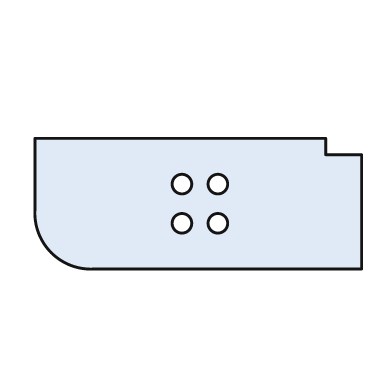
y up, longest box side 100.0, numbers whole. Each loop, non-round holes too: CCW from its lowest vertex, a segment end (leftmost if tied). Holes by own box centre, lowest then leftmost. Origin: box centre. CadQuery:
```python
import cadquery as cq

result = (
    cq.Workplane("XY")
    .moveTo(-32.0, -20.0)
    .lineTo(50.0, -20.0)
    .lineTo(50.0, 15.0)
    .lineTo(39.0, 15.0)
    .lineTo(39.0, 20.0)
    .lineTo(-50.0, 20.0)
    .lineTo(-50.0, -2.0)
    .threePointArc((-45.0, -15.0), (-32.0, -20.0))
    .close()
    .moveTo(-5.0, -6.0)
    .circle(3.0)
    .moveTo(6.0, -6.0)
    .circle(3.0)
    .moveTo(-5.0, 6.0)
    .circle(3.0)
    .moveTo(6.0, 6.0)
    .circle(3.0)
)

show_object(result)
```